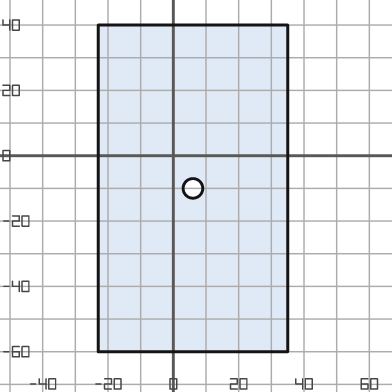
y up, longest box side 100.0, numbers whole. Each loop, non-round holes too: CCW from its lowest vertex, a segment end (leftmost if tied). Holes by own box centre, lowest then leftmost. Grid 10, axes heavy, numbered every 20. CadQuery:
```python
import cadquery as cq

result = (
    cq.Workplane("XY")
    .moveTo(-23.0, -60.0)
    .lineTo(35.0, -60.0)
    .lineTo(35.0, 40.0)
    .lineTo(-23.0, 40.0)
    .close()
    .moveTo(6.0, -10.0)
    .circle(3.0)
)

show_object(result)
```